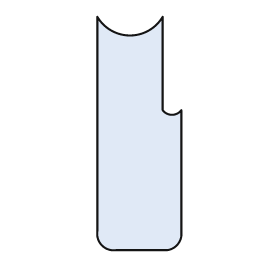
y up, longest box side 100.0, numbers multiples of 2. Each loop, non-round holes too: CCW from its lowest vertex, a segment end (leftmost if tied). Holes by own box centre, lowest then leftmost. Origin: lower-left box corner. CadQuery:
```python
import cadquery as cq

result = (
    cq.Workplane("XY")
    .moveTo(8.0, 0.0)
    .lineTo(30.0, 0.0)
    .threePointArc((34.0, 2.0), (36.0, 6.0))
    .lineTo(36.0, 60.0)
    .threePointArc((32.0, 58.0), (28.0, 60.0))
    .lineTo(28.0, 100.0)
    .threePointArc((14.0, 92.0), (0.0, 100.0))
    .lineTo(0.0, 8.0)
    .threePointArc((2.0, 2.0), (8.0, 0.0))
    .close()
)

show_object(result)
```